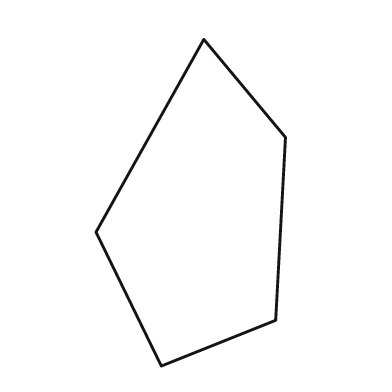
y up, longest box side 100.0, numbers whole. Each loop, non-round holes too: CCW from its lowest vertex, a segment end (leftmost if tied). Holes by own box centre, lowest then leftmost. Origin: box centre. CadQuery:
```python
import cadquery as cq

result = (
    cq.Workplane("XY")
    .moveTo(-9.0, -50.0)
    .lineTo(26.0, -36.0)
    .lineTo(29.0, 20.0)
    .lineTo(4.0, 50.0)
    .lineTo(-29.0, -9.0)
    .close()
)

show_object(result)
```